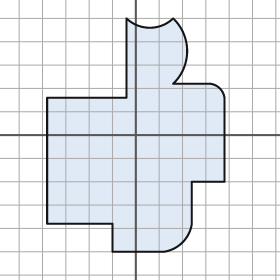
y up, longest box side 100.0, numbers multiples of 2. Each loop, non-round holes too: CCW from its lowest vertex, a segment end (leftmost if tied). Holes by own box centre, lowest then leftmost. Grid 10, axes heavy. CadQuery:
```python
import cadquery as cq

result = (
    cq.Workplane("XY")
    .moveTo(-10.0, -50.0)
    .lineTo(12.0, -50.0)
    .threePointArc((20.0, -46.0), (24.0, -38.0))
    .lineTo(24.0, -20.0)
    .lineTo(38.0, -20.0)
    .lineTo(38.0, 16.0)
    .threePointArc((36.0, 20.0), (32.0, 22.0))
    .lineTo(16.0, 22.0)
    .threePointArc((22.0, 36.0), (16.0, 50.0))
    .threePointArc((6.0, 46.0), (-4.0, 50.0))
    .lineTo(-4.0, 16.0)
    .lineTo(-38.0, 16.0)
    .lineTo(-38.0, -38.0)
    .lineTo(-10.0, -38.0)
    .close()
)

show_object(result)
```